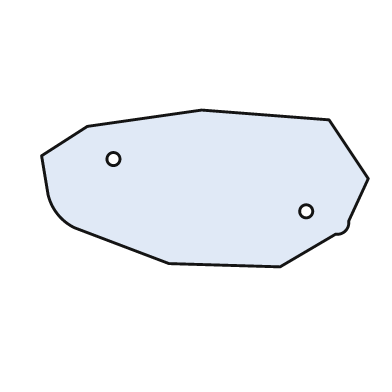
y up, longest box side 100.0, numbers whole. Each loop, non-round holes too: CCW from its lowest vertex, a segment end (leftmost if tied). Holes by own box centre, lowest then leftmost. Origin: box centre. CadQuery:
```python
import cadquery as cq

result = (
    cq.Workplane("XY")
    .moveTo(23.0, -24.0)
    .lineTo(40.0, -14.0)
    .threePointArc((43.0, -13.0), (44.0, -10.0))
    .lineTo(50.0, 3.0)
    .lineTo(38.0, 21.0)
    .lineTo(-1.0, 24.0)
    .lineTo(-36.0, 19.0)
    .lineTo(-50.0, 10.0)
    .lineTo(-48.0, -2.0)
    .threePointArc((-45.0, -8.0), (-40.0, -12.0))
    .lineTo(-11.0, -23.0)
    .close()
    .moveTo(31.0, -7.0)
    .circle(2.0)
    .moveTo(-28.0, 9.0)
    .circle(2.0)
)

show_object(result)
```